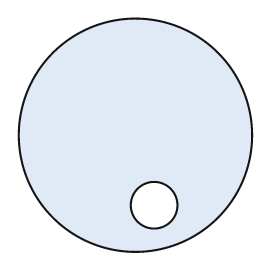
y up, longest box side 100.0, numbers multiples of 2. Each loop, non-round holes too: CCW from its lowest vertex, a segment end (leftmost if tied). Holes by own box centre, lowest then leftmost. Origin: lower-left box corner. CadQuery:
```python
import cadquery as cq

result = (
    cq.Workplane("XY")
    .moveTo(50.0, 50.0)
    .circle(50.0)
    .moveTo(58.0, 20.0)
    .circle(10.0)
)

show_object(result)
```